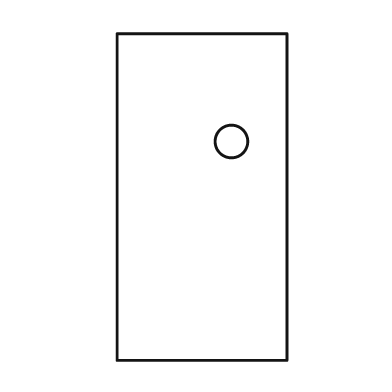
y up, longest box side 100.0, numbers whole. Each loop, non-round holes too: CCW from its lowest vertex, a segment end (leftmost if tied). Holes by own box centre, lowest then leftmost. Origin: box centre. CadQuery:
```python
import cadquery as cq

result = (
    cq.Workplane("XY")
    .moveTo(-26.0, -50.0)
    .lineTo(26.0, -50.0)
    .lineTo(26.0, 50.0)
    .lineTo(-26.0, 50.0)
    .close()
    .moveTo(9.0, 17.0)
    .circle(5.0)
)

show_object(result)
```